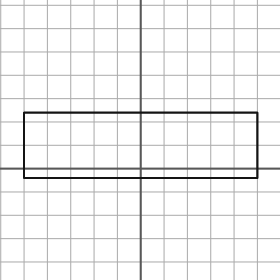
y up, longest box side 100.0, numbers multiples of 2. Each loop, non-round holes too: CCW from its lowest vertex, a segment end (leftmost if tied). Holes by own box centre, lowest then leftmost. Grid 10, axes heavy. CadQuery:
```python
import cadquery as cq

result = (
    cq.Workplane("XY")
    .moveTo(-50.0, -4.0)
    .lineTo(50.0, -4.0)
    .lineTo(50.0, 24.0)
    .lineTo(-50.0, 24.0)
    .close()
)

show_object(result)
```